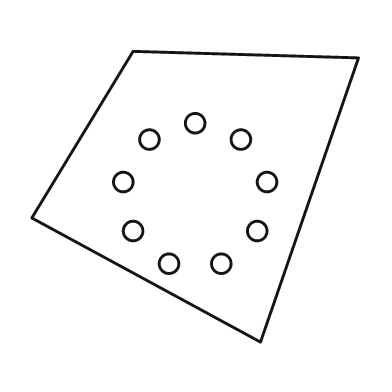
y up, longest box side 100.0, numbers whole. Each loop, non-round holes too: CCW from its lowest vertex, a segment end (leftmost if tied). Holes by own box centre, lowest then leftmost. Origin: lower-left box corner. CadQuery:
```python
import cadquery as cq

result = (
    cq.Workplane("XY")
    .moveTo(70.0, 0.0)
    .lineTo(100.0, 87.0)
    .lineTo(31.0, 89.0)
    .lineTo(0.0, 38.0)
    .close()
    .moveTo(42.0, 24.0)
    .circle(3.0)
    .moveTo(58.0, 24.0)
    .circle(3.0)
    .moveTo(31.0, 34.0)
    .circle(3.0)
    .moveTo(69.0, 34.0)
    .circle(3.0)
    .moveTo(28.0, 49.0)
    .circle(3.0)
    .moveTo(72.0, 49.0)
    .circle(3.0)
    .moveTo(36.0, 62.0)
    .circle(3.0)
    .moveTo(64.0, 62.0)
    .circle(3.0)
    .moveTo(50.0, 67.0)
    .circle(3.0)
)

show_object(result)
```